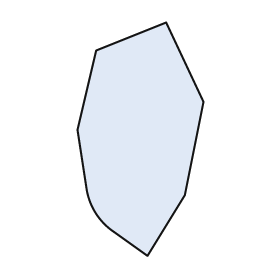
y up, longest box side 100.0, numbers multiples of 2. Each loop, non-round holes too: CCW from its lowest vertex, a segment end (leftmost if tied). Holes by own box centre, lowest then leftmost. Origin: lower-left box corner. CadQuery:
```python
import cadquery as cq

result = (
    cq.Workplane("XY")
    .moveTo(30.0, 0.0)
    .lineTo(46.0, 26.0)
    .lineTo(54.0, 66.0)
    .lineTo(38.0, 100.0)
    .lineTo(8.0, 88.0)
    .lineTo(0.0, 54.0)
    .lineTo(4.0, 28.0)
    .threePointArc((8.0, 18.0), (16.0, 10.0))
    .close()
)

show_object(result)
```